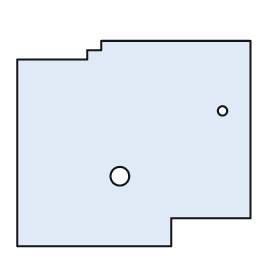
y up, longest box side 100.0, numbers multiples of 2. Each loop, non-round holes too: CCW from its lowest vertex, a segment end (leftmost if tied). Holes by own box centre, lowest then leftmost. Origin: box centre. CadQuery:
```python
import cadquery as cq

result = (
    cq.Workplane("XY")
    .moveTo(-50.0, -44.0)
    .lineTo(16.0, -44.0)
    .lineTo(16.0, -32.0)
    .lineTo(50.0, -32.0)
    .lineTo(50.0, 44.0)
    .lineTo(-14.0, 44.0)
    .lineTo(-14.0, 40.0)
    .lineTo(-20.0, 40.0)
    .lineTo(-20.0, 36.0)
    .lineTo(-50.0, 36.0)
    .close()
    .moveTo(-6.0, -14.0)
    .circle(4.0)
    .moveTo(38.0, 14.0)
    .circle(2.0)
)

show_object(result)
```